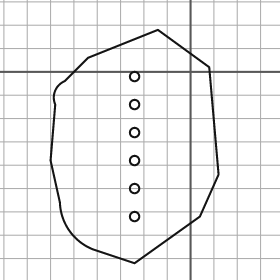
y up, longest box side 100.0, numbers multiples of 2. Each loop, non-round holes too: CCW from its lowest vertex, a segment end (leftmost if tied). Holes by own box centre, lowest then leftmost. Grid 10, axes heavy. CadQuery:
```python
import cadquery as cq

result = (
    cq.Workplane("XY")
    .moveTo(-24.0, -82.0)
    .lineTo(4.0, -62.0)
    .lineTo(12.0, -44.0)
    .lineTo(8.0, 2.0)
    .lineTo(-14.0, 18.0)
    .lineTo(-44.0, 6.0)
    .lineTo(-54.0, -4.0)
    .threePointArc((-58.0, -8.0), (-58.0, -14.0))
    .lineTo(-60.0, -38.0)
    .lineTo(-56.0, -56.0)
    .threePointArc((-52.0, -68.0), (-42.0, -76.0))
    .close()
    .moveTo(-24.0, -62.0)
    .circle(2.0)
    .moveTo(-24.0, -50.0)
    .circle(2.0)
    .moveTo(-24.0, -38.0)
    .circle(2.0)
    .moveTo(-24.0, -26.0)
    .circle(2.0)
    .moveTo(-24.0, -14.0)
    .circle(2.0)
    .moveTo(-24.0, -2.0)
    .circle(2.0)
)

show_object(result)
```